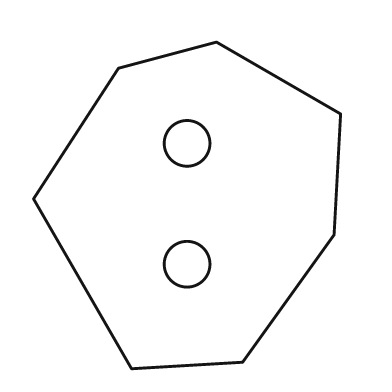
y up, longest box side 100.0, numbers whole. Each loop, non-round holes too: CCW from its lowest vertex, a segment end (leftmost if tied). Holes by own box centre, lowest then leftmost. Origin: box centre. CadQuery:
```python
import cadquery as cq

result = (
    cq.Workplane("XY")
    .moveTo(-17.0, -50.0)
    .lineTo(17.0, -48.0)
    .lineTo(45.0, -9.0)
    .lineTo(47.0, 28.0)
    .lineTo(9.0, 50.0)
    .lineTo(-21.0, 42.0)
    .lineTo(-47.0, 2.0)
    .close()
    .moveTo(0.0, -18.0)
    .circle(7.0)
    .moveTo(0.0, 19.0)
    .circle(7.0)
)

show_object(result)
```